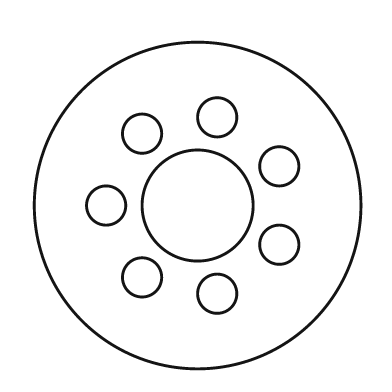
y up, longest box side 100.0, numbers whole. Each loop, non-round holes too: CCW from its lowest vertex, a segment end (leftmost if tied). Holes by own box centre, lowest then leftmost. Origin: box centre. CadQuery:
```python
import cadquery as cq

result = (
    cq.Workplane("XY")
    .moveTo(0.0, 0.0)
    .circle(50.0)
    .moveTo(6.0, -27.0)
    .circle(6.0)
    .moveTo(-17.0, -22.0)
    .circle(6.0)
    .moveTo(25.0, -12.0)
    .circle(6.0)
    .moveTo(-28.0, 0.0)
    .circle(6.0)
    .moveTo(0.0, 0.0)
    .circle(17.0)
    .moveTo(25.0, 12.0)
    .circle(6.0)
    .moveTo(-17.0, 22.0)
    .circle(6.0)
    .moveTo(6.0, 27.0)
    .circle(6.0)
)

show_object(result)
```